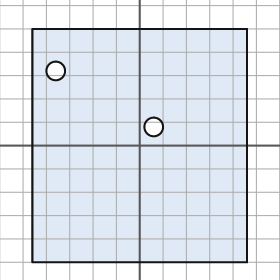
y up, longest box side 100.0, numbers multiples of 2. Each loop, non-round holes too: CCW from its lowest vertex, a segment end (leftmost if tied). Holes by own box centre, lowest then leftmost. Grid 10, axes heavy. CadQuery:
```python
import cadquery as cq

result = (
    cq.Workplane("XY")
    .moveTo(-46.0, -50.0)
    .lineTo(46.0, -50.0)
    .lineTo(46.0, 50.0)
    .lineTo(-46.0, 50.0)
    .close()
    .moveTo(6.0, 8.0)
    .circle(4.0)
    .moveTo(-36.0, 32.0)
    .circle(4.0)
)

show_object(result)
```